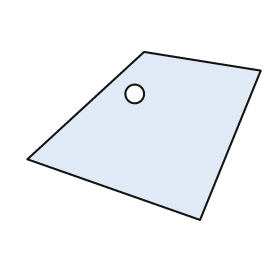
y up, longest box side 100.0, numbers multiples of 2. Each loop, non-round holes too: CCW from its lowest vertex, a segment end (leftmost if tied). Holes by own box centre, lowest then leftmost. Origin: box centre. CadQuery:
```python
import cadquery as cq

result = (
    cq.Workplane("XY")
    .moveTo(24.0, -36.0)
    .lineTo(50.0, 28.0)
    .lineTo(0.0, 36.0)
    .lineTo(-50.0, -10.0)
    .close()
    .moveTo(-4.0, 18.0)
    .circle(4.0)
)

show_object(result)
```